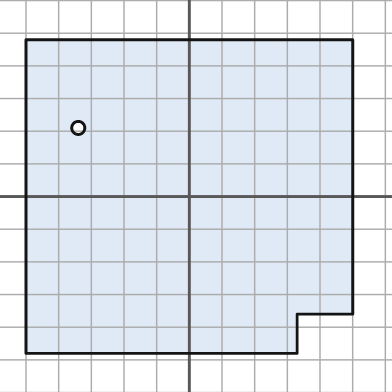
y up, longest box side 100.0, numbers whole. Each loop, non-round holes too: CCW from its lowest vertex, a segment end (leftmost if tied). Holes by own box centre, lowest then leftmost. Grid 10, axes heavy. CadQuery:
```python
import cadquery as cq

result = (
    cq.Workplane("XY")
    .moveTo(-50.0, -48.0)
    .lineTo(33.0, -48.0)
    .lineTo(33.0, -36.0)
    .lineTo(50.0, -36.0)
    .lineTo(50.0, 48.0)
    .lineTo(-50.0, 48.0)
    .close()
    .moveTo(-34.0, 21.0)
    .circle(2.0)
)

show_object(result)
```